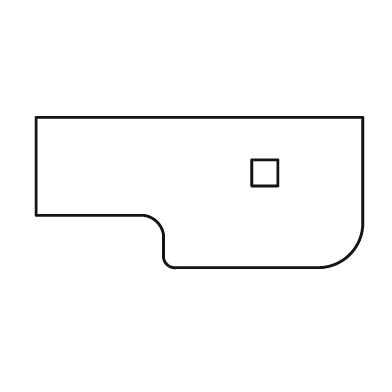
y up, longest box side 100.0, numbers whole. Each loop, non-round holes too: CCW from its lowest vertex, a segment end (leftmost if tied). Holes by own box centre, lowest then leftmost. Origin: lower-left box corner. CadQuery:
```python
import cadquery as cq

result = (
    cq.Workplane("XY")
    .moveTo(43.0, 0.0)
    .lineTo(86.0, 0.0)
    .threePointArc((96.0, 4.0), (100.0, 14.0))
    .lineTo(100.0, 46.0)
    .lineTo(0.0, 46.0)
    .lineTo(0.0, 16.0)
    .lineTo(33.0, 16.0)
    .threePointArc((37.0, 14.0), (39.0, 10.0))
    .lineTo(39.0, 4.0)
    .threePointArc((40.0, 1.0), (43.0, 0.0))
    .close()
    .moveTo(66.0, 25.0)
    .lineTo(74.0, 25.0)
    .lineTo(74.0, 33.0)
    .lineTo(66.0, 33.0)
    .close()
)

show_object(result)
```